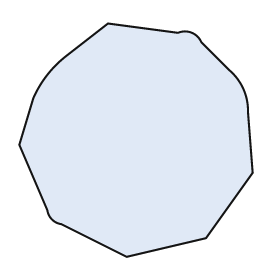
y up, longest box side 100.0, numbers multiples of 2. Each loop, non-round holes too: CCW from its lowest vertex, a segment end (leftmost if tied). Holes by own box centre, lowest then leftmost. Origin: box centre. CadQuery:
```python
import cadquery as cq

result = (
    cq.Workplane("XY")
    .moveTo(-4.0, -50.0)
    .lineTo(30.0, -42.0)
    .lineTo(50.0, -14.0)
    .lineTo(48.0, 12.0)
    .threePointArc((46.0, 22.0), (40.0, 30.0))
    .lineTo(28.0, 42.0)
    .threePointArc((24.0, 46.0), (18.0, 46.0))
    .lineTo(-12.0, 50.0)
    .lineTo(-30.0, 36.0)
    .threePointArc((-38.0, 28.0), (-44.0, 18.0))
    .lineTo(-50.0, -2.0)
    .lineTo(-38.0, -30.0)
    .threePointArc((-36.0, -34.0), (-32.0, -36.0))
    .close()
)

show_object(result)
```